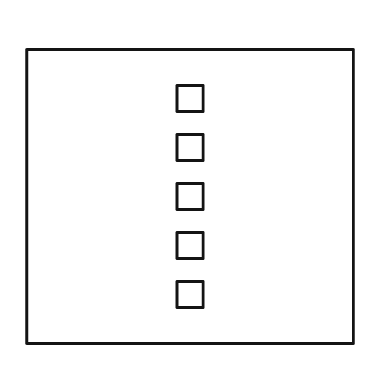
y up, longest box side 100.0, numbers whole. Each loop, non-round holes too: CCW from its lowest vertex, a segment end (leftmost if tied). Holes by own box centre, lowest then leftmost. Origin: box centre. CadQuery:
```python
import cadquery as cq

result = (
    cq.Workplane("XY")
    .moveTo(-50.0, -45.0)
    .lineTo(50.0, -45.0)
    .lineTo(50.0, 45.0)
    .lineTo(-50.0, 45.0)
    .close()
    .moveTo(-4.0, -34.0)
    .lineTo(4.0, -34.0)
    .lineTo(4.0, -26.0)
    .lineTo(-4.0, -26.0)
    .close()
    .moveTo(-4.0, -19.0)
    .lineTo(4.0, -19.0)
    .lineTo(4.0, -11.0)
    .lineTo(-4.0, -11.0)
    .close()
    .moveTo(-4.0, -4.0)
    .lineTo(4.0, -4.0)
    .lineTo(4.0, 4.0)
    .lineTo(-4.0, 4.0)
    .close()
    .moveTo(-4.0, 11.0)
    .lineTo(4.0, 11.0)
    .lineTo(4.0, 19.0)
    .lineTo(-4.0, 19.0)
    .close()
    .moveTo(-4.0, 26.0)
    .lineTo(4.0, 26.0)
    .lineTo(4.0, 34.0)
    .lineTo(-4.0, 34.0)
    .close()
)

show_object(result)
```